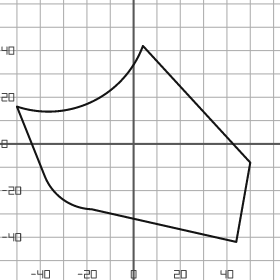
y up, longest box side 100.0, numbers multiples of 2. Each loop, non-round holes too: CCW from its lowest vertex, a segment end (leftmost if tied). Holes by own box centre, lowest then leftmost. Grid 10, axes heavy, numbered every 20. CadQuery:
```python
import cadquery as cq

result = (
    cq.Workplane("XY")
    .moveTo(44.0, -42.0)
    .lineTo(50.0, -8.0)
    .lineTo(4.0, 42.0)
    .threePointArc((-18.0, 18.0), (-50.0, 16.0))
    .lineTo(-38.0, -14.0)
    .threePointArc((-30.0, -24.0), (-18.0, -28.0))
    .close()
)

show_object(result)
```